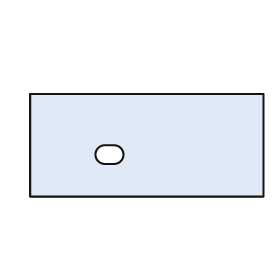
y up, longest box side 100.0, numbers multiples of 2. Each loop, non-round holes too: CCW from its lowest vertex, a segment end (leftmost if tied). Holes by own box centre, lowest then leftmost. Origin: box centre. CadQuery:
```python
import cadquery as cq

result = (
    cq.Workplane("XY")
    .moveTo(-50.0, -22.0)
    .lineTo(50.0, -22.0)
    .lineTo(50.0, 22.0)
    .lineTo(-50.0, 22.0)
    .close()
    .moveTo(-18.0, -8.0)
    .lineTo(-14.0, -8.0)
    .threePointArc((-10.0, -4.0), (-14.0, 0.0))
    .lineTo(-18.0, 0.0)
    .threePointArc((-22.0, -4.0), (-18.0, -8.0))
    .close()
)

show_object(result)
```